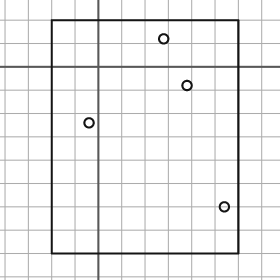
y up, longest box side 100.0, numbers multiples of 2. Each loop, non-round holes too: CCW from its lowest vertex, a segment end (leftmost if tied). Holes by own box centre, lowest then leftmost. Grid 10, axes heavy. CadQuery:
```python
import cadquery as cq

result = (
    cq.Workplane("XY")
    .moveTo(-20.0, -80.0)
    .lineTo(60.0, -80.0)
    .lineTo(60.0, 20.0)
    .lineTo(-20.0, 20.0)
    .close()
    .moveTo(54.0, -60.0)
    .circle(2.0)
    .moveTo(-4.0, -24.0)
    .circle(2.0)
    .moveTo(38.0, -8.0)
    .circle(2.0)
    .moveTo(28.0, 12.0)
    .circle(2.0)
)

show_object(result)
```